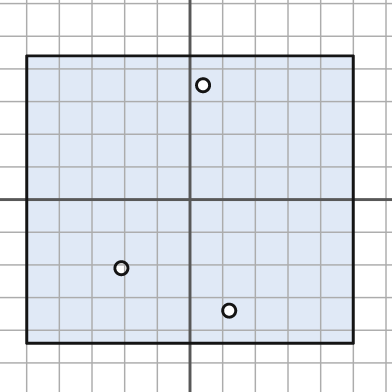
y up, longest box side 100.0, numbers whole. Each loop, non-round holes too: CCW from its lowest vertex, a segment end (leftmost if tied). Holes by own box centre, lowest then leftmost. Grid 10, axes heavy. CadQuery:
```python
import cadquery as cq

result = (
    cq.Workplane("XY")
    .moveTo(-50.0, -44.0)
    .lineTo(50.0, -44.0)
    .lineTo(50.0, 44.0)
    .lineTo(-50.0, 44.0)
    .close()
    .moveTo(12.0, -34.0)
    .circle(2.0)
    .moveTo(-21.0, -21.0)
    .circle(2.0)
    .moveTo(4.0, 35.0)
    .circle(2.0)
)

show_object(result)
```